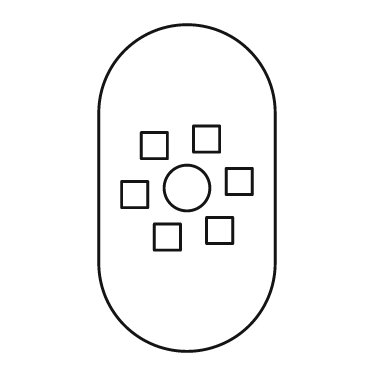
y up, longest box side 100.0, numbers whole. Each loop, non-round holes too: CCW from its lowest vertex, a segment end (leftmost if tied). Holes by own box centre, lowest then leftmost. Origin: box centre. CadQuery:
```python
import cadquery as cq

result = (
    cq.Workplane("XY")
    .moveTo(-27.0, -23.0)
    .threePointArc((0.0, -50.0), (27.0, -23.0))
    .lineTo(27.0, 23.0)
    .threePointArc((0.0, 50.0), (-27.0, 23.0))
    .close()
    .moveTo(-10.0, -19.0)
    .lineTo(-2.0, -19.0)
    .lineTo(-2.0, -11.0)
    .lineTo(-10.0, -11.0)
    .close()
    .moveTo(6.0, -17.0)
    .lineTo(14.0, -17.0)
    .lineTo(14.0, -9.0)
    .lineTo(6.0, -9.0)
    .close()
    .moveTo(-20.0, -6.0)
    .lineTo(-12.0, -6.0)
    .lineTo(-12.0, 2.0)
    .lineTo(-20.0, 2.0)
    .close()
    .moveTo(0.0, 0.0)
    .circle(7.0)
    .moveTo(12.0, -2.0)
    .lineTo(20.0, -2.0)
    .lineTo(20.0, 6.0)
    .lineTo(12.0, 6.0)
    .close()
    .moveTo(-14.0, 9.0)
    .lineTo(-6.0, 9.0)
    .lineTo(-6.0, 17.0)
    .lineTo(-14.0, 17.0)
    .close()
    .moveTo(2.0, 11.0)
    .lineTo(10.0, 11.0)
    .lineTo(10.0, 19.0)
    .lineTo(2.0, 19.0)
    .close()
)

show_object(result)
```